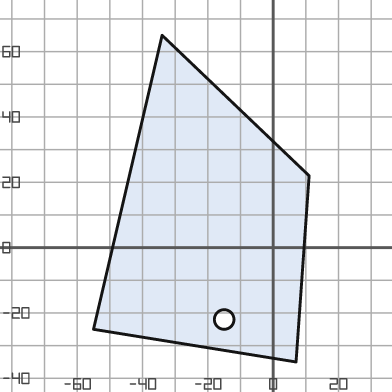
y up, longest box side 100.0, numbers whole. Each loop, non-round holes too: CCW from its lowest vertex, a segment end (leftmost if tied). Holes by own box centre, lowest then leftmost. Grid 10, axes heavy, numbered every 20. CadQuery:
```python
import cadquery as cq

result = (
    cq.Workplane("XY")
    .moveTo(7.0, -35.0)
    .lineTo(11.0, 22.0)
    .lineTo(-34.0, 65.0)
    .lineTo(-55.0, -25.0)
    .close()
    .moveTo(-15.0, -22.0)
    .circle(3.0)
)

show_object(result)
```